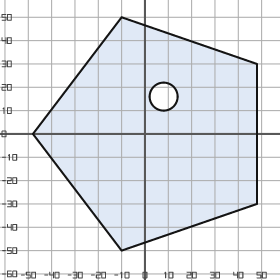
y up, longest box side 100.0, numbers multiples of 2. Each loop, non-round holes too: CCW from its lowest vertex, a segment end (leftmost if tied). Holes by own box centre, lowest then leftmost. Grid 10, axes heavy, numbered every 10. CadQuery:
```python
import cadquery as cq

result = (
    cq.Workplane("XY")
    .moveTo(-10.0, -50.0)
    .lineTo(48.0, -30.0)
    .lineTo(48.0, 30.0)
    .lineTo(-10.0, 50.0)
    .lineTo(-48.0, 0.0)
    .close()
    .moveTo(8.0, 16.0)
    .circle(6.0)
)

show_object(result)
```